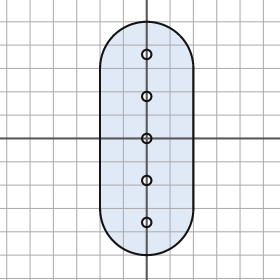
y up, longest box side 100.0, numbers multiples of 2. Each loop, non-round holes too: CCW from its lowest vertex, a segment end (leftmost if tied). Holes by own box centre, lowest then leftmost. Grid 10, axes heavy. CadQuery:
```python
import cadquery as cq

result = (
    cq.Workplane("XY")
    .moveTo(-20.0, -30.0)
    .threePointArc((0.0, -50.0), (20.0, -30.0))
    .lineTo(20.0, 30.0)
    .threePointArc((0.0, 50.0), (-20.0, 30.0))
    .close()
    .moveTo(0.0, -36.0)
    .circle(2.0)
    .moveTo(0.0, -18.0)
    .circle(2.0)
    .moveTo(0.0, 0.0)
    .circle(2.0)
    .moveTo(0.0, 18.0)
    .circle(2.0)
    .moveTo(0.0, 36.0)
    .circle(2.0)
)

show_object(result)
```